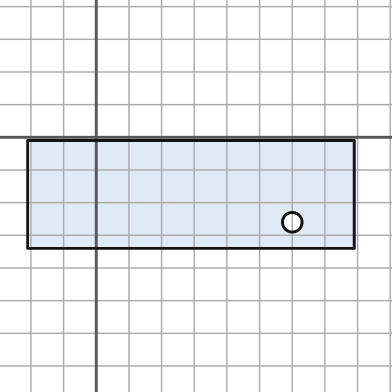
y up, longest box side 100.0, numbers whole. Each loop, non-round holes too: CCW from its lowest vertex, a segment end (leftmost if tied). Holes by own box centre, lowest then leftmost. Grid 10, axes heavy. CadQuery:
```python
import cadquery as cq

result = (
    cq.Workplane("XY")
    .moveTo(-21.0, -34.0)
    .lineTo(79.0, -34.0)
    .lineTo(79.0, -1.0)
    .lineTo(-21.0, -1.0)
    .close()
    .moveTo(60.0, -26.0)
    .circle(3.0)
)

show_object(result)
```